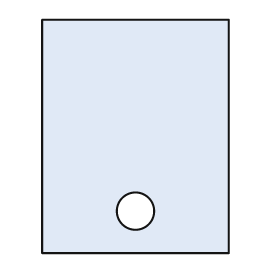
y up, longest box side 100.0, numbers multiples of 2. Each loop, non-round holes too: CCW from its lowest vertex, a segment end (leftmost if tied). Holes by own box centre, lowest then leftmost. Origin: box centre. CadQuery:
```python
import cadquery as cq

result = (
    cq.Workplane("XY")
    .moveTo(-40.0, -50.0)
    .lineTo(40.0, -50.0)
    .lineTo(40.0, 50.0)
    .lineTo(-40.0, 50.0)
    .close()
    .moveTo(0.0, -32.0)
    .circle(8.0)
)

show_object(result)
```